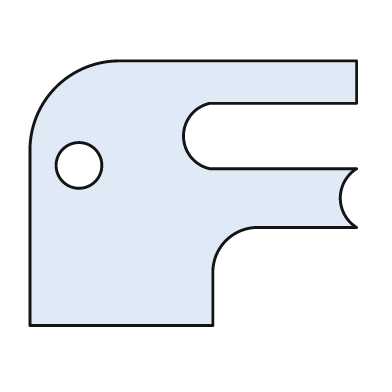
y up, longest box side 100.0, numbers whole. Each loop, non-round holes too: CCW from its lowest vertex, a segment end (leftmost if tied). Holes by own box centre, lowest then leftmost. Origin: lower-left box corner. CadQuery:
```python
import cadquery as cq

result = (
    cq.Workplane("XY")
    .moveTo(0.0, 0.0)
    .lineTo(56.0, 0.0)
    .lineTo(56.0, 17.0)
    .threePointArc((60.0, 26.0), (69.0, 30.0))
    .lineTo(100.0, 30.0)
    .threePointArc((95.0, 39.0), (100.0, 48.0))
    .lineTo(55.0, 48.0)
    .threePointArc((47.0, 58.0), (55.0, 68.0))
    .lineTo(100.0, 68.0)
    .lineTo(100.0, 81.0)
    .lineTo(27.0, 81.0)
    .threePointArc((8.0, 73.0), (0.0, 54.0))
    .close()
    .moveTo(15.0, 49.0)
    .circle(7.0)
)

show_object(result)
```